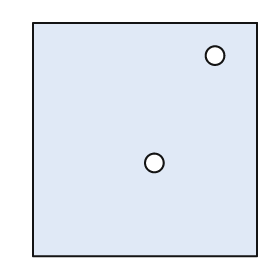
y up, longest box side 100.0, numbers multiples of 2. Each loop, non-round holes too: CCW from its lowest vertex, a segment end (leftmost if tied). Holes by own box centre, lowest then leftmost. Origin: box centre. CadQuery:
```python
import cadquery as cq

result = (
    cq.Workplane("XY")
    .moveTo(-48.0, -50.0)
    .lineTo(48.0, -50.0)
    .lineTo(48.0, 50.0)
    .lineTo(-48.0, 50.0)
    .close()
    .moveTo(4.0, -10.0)
    .circle(4.0)
    .moveTo(30.0, 36.0)
    .circle(4.0)
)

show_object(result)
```